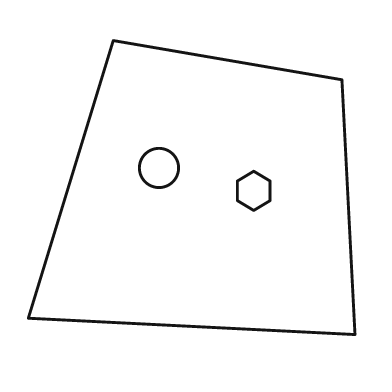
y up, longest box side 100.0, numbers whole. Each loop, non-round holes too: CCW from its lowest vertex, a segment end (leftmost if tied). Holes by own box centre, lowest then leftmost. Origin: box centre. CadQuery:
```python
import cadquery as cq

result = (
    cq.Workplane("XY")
    .moveTo(50.0, -45.0)
    .lineTo(46.0, 33.0)
    .lineTo(-24.0, 45.0)
    .lineTo(-50.0, -40.0)
    .close()
    .moveTo(19.0, -7.0)
    .lineTo(24.0, -4.0)
    .lineTo(24.0, 2.0)
    .lineTo(19.0, 5.0)
    .lineTo(14.0, 2.0)
    .lineTo(14.0, -4.0)
    .close()
    .moveTo(-10.0, 6.0)
    .circle(6.0)
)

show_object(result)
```